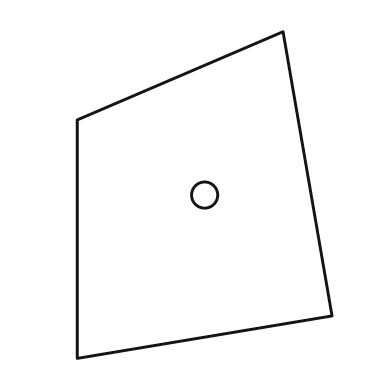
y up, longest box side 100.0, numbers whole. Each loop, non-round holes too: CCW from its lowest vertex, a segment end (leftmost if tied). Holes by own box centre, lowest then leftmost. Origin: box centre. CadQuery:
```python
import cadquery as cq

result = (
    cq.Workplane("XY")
    .moveTo(-39.0, -50.0)
    .lineTo(39.0, -37.0)
    .lineTo(24.0, 50.0)
    .lineTo(-39.0, 23.0)
    .close()
    .moveTo(0.0, 0.0)
    .circle(4.0)
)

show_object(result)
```